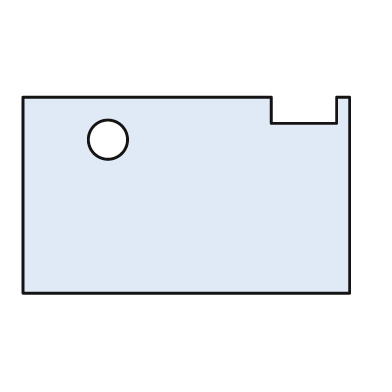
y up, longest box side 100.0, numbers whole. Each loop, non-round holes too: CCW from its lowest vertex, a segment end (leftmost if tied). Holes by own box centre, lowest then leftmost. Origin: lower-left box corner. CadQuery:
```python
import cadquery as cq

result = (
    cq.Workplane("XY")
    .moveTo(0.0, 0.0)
    .lineTo(100.0, 0.0)
    .lineTo(100.0, 60.0)
    .lineTo(96.0, 60.0)
    .lineTo(96.0, 52.0)
    .lineTo(76.0, 52.0)
    .lineTo(76.0, 60.0)
    .lineTo(0.0, 60.0)
    .close()
    .moveTo(26.0, 47.0)
    .circle(6.0)
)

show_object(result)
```